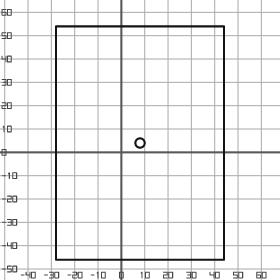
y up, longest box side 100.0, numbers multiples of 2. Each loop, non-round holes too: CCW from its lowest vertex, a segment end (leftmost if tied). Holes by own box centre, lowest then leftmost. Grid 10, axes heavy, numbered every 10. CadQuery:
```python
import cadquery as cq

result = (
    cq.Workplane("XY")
    .moveTo(-28.0, -46.0)
    .lineTo(44.0, -46.0)
    .lineTo(44.0, 54.0)
    .lineTo(-28.0, 54.0)
    .close()
    .moveTo(8.0, 4.0)
    .circle(2.0)
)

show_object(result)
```